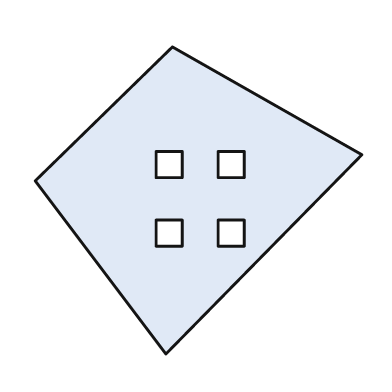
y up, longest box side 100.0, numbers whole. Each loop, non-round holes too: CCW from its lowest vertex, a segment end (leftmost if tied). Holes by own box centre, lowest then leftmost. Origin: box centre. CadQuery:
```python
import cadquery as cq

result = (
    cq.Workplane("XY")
    .moveTo(-10.0, -47.0)
    .lineTo(50.0, 14.0)
    .lineTo(-8.0, 47.0)
    .lineTo(-50.0, 6.0)
    .close()
    .moveTo(-13.0, -14.0)
    .lineTo(-5.0, -14.0)
    .lineTo(-5.0, -6.0)
    .lineTo(-13.0, -6.0)
    .close()
    .moveTo(6.0, -14.0)
    .lineTo(14.0, -14.0)
    .lineTo(14.0, -6.0)
    .lineTo(6.0, -6.0)
    .close()
    .moveTo(-13.0, 7.0)
    .lineTo(-5.0, 7.0)
    .lineTo(-5.0, 15.0)
    .lineTo(-13.0, 15.0)
    .close()
    .moveTo(6.0, 7.0)
    .lineTo(14.0, 7.0)
    .lineTo(14.0, 15.0)
    .lineTo(6.0, 15.0)
    .close()
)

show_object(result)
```